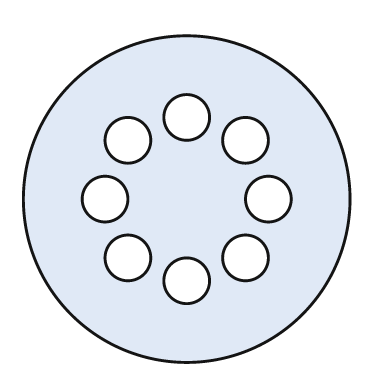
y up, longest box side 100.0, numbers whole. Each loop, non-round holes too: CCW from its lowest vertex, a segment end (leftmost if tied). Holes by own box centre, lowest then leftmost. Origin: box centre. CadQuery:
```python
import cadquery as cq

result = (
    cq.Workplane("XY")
    .moveTo(0.0, 0.0)
    .circle(50.0)
    .moveTo(0.0, -25.0)
    .circle(7.0)
    .moveTo(-18.0, -18.0)
    .circle(7.0)
    .moveTo(18.0, -18.0)
    .circle(7.0)
    .moveTo(-25.0, 0.0)
    .circle(7.0)
    .moveTo(25.0, 0.0)
    .circle(7.0)
    .moveTo(-18.0, 18.0)
    .circle(7.0)
    .moveTo(18.0, 18.0)
    .circle(7.0)
    .moveTo(0.0, 25.0)
    .circle(7.0)
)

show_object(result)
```